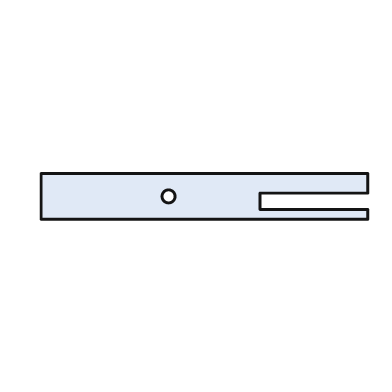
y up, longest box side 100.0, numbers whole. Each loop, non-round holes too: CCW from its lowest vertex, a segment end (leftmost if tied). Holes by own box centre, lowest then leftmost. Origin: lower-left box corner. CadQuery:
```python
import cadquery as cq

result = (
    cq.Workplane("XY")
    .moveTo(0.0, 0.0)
    .lineTo(100.0, 0.0)
    .lineTo(100.0, 3.0)
    .lineTo(67.0, 3.0)
    .lineTo(67.0, 8.0)
    .lineTo(100.0, 8.0)
    .lineTo(100.0, 14.0)
    .lineTo(0.0, 14.0)
    .close()
    .moveTo(39.0, 7.0)
    .circle(2.0)
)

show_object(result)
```